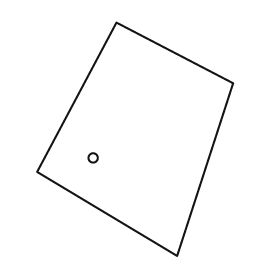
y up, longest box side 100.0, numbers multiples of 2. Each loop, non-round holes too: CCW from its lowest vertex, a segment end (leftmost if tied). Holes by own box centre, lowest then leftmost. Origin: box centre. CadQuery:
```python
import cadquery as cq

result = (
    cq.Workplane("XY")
    .moveTo(18.0, -50.0)
    .lineTo(42.0, 24.0)
    .lineTo(-8.0, 50.0)
    .lineTo(-42.0, -14.0)
    .close()
    .moveTo(-18.0, -8.0)
    .circle(2.0)
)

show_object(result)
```